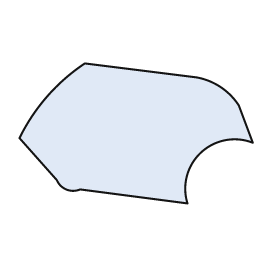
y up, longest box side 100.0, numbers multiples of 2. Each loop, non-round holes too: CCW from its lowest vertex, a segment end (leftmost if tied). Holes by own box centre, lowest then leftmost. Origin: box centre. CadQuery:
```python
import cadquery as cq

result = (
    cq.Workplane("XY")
    .moveTo(22.0, -30.0)
    .threePointArc((28.0, -8.0), (50.0, -4.0))
    .lineTo(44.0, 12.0)
    .threePointArc((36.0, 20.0), (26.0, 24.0))
    .lineTo(-22.0, 30.0)
    .threePointArc((-38.0, 16.0), (-50.0, -2.0))
    .lineTo(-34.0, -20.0)
    .threePointArc((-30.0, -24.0), (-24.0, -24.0))
    .close()
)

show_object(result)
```